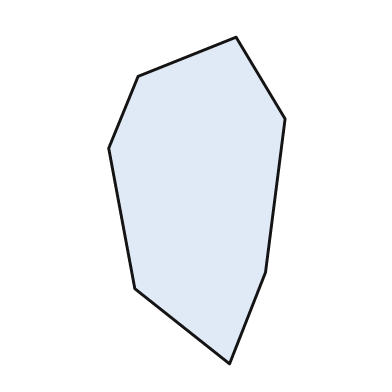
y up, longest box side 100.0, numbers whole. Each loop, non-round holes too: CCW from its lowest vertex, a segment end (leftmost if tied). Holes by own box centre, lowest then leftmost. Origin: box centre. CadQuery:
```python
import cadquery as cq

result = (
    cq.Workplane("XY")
    .moveTo(10.0, -50.0)
    .lineTo(21.0, -22.0)
    .lineTo(27.0, 25.0)
    .lineTo(12.0, 50.0)
    .lineTo(-18.0, 38.0)
    .lineTo(-27.0, 16.0)
    .lineTo(-19.0, -27.0)
    .close()
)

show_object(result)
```